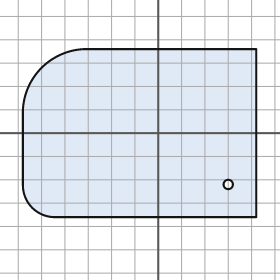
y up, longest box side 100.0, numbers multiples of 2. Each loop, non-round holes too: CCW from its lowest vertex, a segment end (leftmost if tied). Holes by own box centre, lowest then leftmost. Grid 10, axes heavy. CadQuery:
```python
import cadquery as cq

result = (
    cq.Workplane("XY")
    .moveTo(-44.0, -36.0)
    .lineTo(42.0, -36.0)
    .lineTo(42.0, 36.0)
    .lineTo(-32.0, 36.0)
    .threePointArc((-50.0, 28.0), (-58.0, 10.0))
    .lineTo(-58.0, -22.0)
    .threePointArc((-54.0, -32.0), (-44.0, -36.0))
    .close()
    .moveTo(30.0, -22.0)
    .circle(2.0)
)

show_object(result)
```